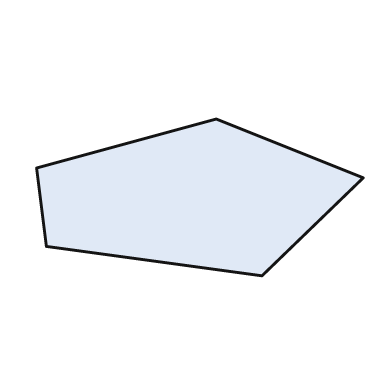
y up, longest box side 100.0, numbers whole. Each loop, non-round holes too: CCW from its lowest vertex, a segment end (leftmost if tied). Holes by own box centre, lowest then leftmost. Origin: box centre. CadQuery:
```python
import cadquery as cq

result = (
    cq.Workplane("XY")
    .moveTo(19.0, -24.0)
    .lineTo(50.0, 6.0)
    .lineTo(5.0, 24.0)
    .lineTo(-50.0, 9.0)
    .lineTo(-47.0, -15.0)
    .close()
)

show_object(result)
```